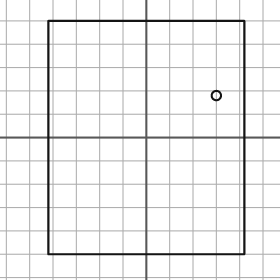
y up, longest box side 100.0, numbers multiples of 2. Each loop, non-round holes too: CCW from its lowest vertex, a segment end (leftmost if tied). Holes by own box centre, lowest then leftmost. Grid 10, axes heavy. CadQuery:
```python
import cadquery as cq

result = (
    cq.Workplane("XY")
    .moveTo(-42.0, -50.0)
    .lineTo(42.0, -50.0)
    .lineTo(42.0, 50.0)
    .lineTo(-42.0, 50.0)
    .close()
    .moveTo(30.0, 18.0)
    .circle(2.0)
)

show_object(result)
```